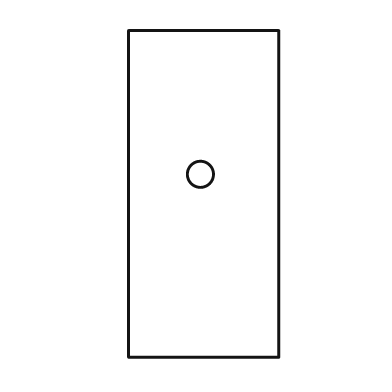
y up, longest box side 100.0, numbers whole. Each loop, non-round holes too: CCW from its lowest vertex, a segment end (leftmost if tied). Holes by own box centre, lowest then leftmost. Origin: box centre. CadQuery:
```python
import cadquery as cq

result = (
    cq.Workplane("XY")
    .moveTo(-23.0, -50.0)
    .lineTo(23.0, -50.0)
    .lineTo(23.0, 50.0)
    .lineTo(-23.0, 50.0)
    .close()
    .moveTo(-1.0, 6.0)
    .circle(4.0)
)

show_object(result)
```